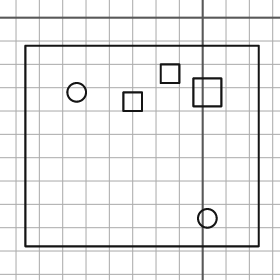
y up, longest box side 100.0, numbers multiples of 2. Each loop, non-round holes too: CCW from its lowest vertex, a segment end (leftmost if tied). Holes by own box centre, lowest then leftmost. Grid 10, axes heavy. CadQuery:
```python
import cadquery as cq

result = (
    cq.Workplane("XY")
    .moveTo(-76.0, -98.0)
    .lineTo(24.0, -98.0)
    .lineTo(24.0, -12.0)
    .lineTo(-76.0, -12.0)
    .close()
    .moveTo(2.0, -86.0)
    .circle(4.0)
    .moveTo(-34.0, -40.0)
    .lineTo(-26.0, -40.0)
    .lineTo(-26.0, -32.0)
    .lineTo(-34.0, -32.0)
    .close()
    .moveTo(-54.0, -32.0)
    .circle(4.0)
    .moveTo(-4.0, -38.0)
    .lineTo(8.0, -38.0)
    .lineTo(8.0, -26.0)
    .lineTo(-4.0, -26.0)
    .close()
    .moveTo(-18.0, -28.0)
    .lineTo(-10.0, -28.0)
    .lineTo(-10.0, -20.0)
    .lineTo(-18.0, -20.0)
    .close()
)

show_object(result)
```